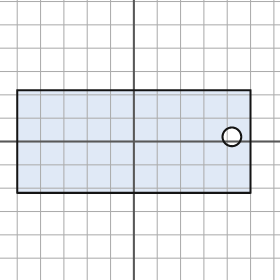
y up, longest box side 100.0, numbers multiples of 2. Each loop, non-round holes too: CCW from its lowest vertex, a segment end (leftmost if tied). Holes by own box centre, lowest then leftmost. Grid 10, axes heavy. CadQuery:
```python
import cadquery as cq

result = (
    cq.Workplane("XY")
    .moveTo(-50.0, -22.0)
    .lineTo(50.0, -22.0)
    .lineTo(50.0, 22.0)
    .lineTo(-50.0, 22.0)
    .close()
    .moveTo(42.0, 2.0)
    .circle(4.0)
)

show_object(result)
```